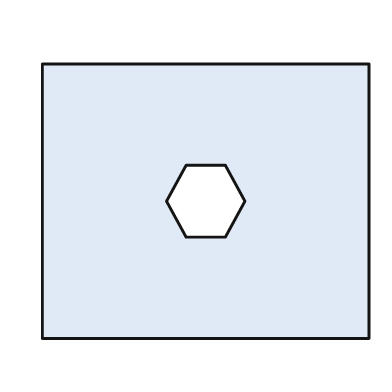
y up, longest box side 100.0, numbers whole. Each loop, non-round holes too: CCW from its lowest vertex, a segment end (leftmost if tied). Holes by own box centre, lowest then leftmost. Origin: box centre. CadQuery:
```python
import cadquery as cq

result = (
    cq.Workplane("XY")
    .moveTo(-50.0, -42.0)
    .lineTo(50.0, -42.0)
    .lineTo(50.0, 42.0)
    .lineTo(-50.0, 42.0)
    .close()
    .moveTo(-6.0, -11.0)
    .lineTo(6.0, -11.0)
    .lineTo(12.0, 0.0)
    .lineTo(6.0, 11.0)
    .lineTo(-6.0, 11.0)
    .lineTo(-12.0, 0.0)
    .close()
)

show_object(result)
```